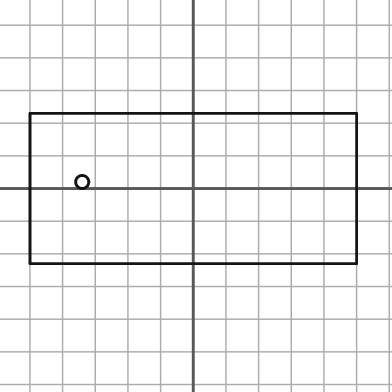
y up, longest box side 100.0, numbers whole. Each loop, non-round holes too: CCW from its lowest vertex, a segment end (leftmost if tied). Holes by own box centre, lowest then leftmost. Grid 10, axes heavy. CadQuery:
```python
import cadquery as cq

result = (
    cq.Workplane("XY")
    .moveTo(-50.0, -23.0)
    .lineTo(50.0, -23.0)
    .lineTo(50.0, 23.0)
    .lineTo(-50.0, 23.0)
    .close()
    .moveTo(-34.0, 2.0)
    .circle(2.0)
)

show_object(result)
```